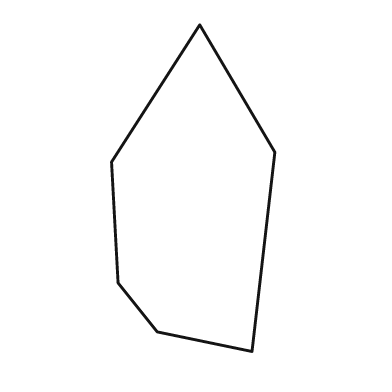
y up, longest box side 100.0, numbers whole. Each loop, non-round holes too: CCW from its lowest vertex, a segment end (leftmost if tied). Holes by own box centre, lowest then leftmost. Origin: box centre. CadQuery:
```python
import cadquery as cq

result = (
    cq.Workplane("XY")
    .moveTo(18.0, -50.0)
    .lineTo(25.0, 11.0)
    .lineTo(2.0, 50.0)
    .lineTo(-25.0, 8.0)
    .lineTo(-23.0, -29.0)
    .lineTo(-11.0, -44.0)
    .close()
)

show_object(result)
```